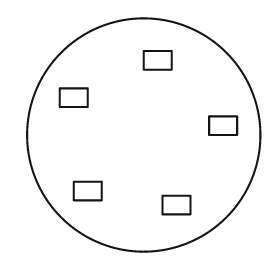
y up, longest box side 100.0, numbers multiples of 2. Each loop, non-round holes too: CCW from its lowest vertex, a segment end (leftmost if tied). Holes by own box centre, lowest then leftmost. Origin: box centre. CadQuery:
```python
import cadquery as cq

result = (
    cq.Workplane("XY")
    .moveTo(0.0, 0.0)
    .circle(50.0)
    .moveTo(8.0, -34.0)
    .lineTo(20.0, -34.0)
    .lineTo(20.0, -26.0)
    .lineTo(8.0, -26.0)
    .close()
    .moveTo(-30.0, -28.0)
    .lineTo(-18.0, -28.0)
    .lineTo(-18.0, -20.0)
    .lineTo(-30.0, -20.0)
    .close()
    .moveTo(28.0, 0.0)
    .lineTo(40.0, 0.0)
    .lineTo(40.0, 8.0)
    .lineTo(28.0, 8.0)
    .close()
    .moveTo(-36.0, 12.0)
    .lineTo(-24.0, 12.0)
    .lineTo(-24.0, 20.0)
    .lineTo(-36.0, 20.0)
    .close()
    .moveTo(0.0, 28.0)
    .lineTo(12.0, 28.0)
    .lineTo(12.0, 36.0)
    .lineTo(0.0, 36.0)
    .close()
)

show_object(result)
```